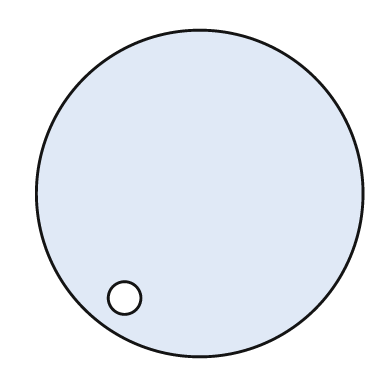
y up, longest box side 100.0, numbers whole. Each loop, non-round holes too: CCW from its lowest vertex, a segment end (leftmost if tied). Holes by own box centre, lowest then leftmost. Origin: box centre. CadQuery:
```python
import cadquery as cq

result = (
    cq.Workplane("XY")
    .moveTo(0.0, 0.0)
    .circle(50.0)
    .moveTo(-23.0, -32.0)
    .circle(5.0)
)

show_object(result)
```